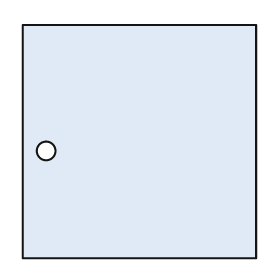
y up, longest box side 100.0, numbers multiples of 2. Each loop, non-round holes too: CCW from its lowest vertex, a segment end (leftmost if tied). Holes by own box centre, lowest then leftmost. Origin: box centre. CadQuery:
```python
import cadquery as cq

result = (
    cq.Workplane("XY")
    .moveTo(-50.0, -50.0)
    .lineTo(50.0, -50.0)
    .lineTo(50.0, 50.0)
    .lineTo(-50.0, 50.0)
    .close()
    .moveTo(-40.0, -4.0)
    .circle(4.0)
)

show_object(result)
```